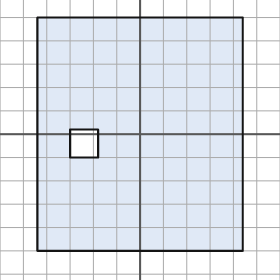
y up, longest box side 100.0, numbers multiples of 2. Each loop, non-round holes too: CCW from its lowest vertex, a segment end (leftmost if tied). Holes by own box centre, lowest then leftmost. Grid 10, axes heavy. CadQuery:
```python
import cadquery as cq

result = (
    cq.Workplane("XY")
    .moveTo(-44.0, -50.0)
    .lineTo(44.0, -50.0)
    .lineTo(44.0, 50.0)
    .lineTo(-44.0, 50.0)
    .close()
    .moveTo(-30.0, -10.0)
    .lineTo(-18.0, -10.0)
    .lineTo(-18.0, 2.0)
    .lineTo(-30.0, 2.0)
    .close()
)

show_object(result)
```